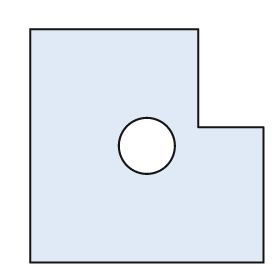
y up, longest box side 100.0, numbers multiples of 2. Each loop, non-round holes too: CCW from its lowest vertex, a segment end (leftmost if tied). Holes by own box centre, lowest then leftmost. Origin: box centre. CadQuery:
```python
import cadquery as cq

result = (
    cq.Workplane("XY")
    .moveTo(-50.0, -50.0)
    .lineTo(50.0, -50.0)
    .lineTo(50.0, 8.0)
    .lineTo(22.0, 8.0)
    .lineTo(22.0, 50.0)
    .lineTo(-50.0, 50.0)
    .close()
    .moveTo(0.0, 0.0)
    .circle(12.0)
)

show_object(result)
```